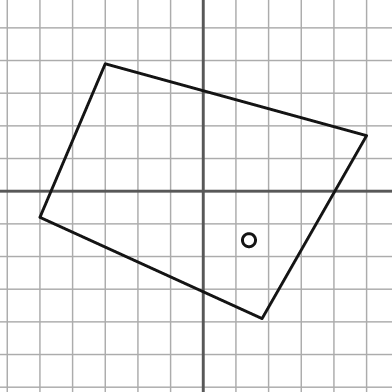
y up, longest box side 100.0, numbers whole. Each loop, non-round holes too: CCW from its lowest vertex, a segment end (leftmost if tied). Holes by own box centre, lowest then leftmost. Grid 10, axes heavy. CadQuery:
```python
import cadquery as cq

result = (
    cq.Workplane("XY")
    .moveTo(18.0, -39.0)
    .lineTo(50.0, 17.0)
    .lineTo(-30.0, 39.0)
    .lineTo(-50.0, -8.0)
    .close()
    .moveTo(14.0, -15.0)
    .circle(2.0)
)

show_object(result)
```